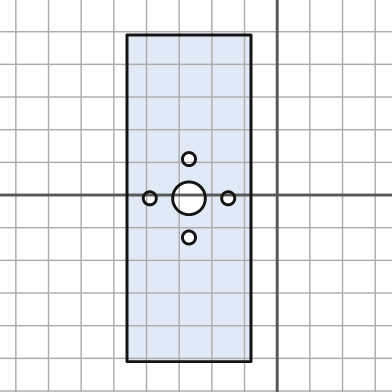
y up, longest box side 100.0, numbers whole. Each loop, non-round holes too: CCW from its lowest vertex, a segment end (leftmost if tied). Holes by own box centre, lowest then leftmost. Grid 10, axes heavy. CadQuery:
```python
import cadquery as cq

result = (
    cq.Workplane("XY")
    .moveTo(-46.0, -51.0)
    .lineTo(-8.0, -51.0)
    .lineTo(-8.0, 49.0)
    .lineTo(-46.0, 49.0)
    .close()
    .moveTo(-27.0, -13.0)
    .circle(2.0)
    .moveTo(-39.0, -1.0)
    .circle(2.0)
    .moveTo(-27.0, -1.0)
    .circle(5.0)
    .moveTo(-15.0, -1.0)
    .circle(2.0)
    .moveTo(-27.0, 11.0)
    .circle(2.0)
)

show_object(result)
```